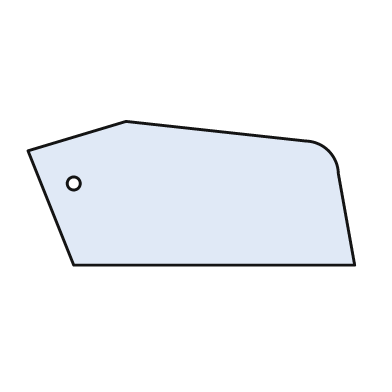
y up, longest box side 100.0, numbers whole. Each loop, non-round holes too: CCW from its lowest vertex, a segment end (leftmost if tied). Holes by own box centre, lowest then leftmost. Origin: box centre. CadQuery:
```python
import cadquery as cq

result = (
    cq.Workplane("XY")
    .moveTo(-36.0, -22.0)
    .lineTo(50.0, -22.0)
    .lineTo(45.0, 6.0)
    .threePointArc((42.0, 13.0), (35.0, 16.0))
    .lineTo(-20.0, 22.0)
    .lineTo(-50.0, 13.0)
    .close()
    .moveTo(-36.0, 3.0)
    .circle(2.0)
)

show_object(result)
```